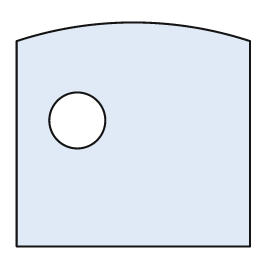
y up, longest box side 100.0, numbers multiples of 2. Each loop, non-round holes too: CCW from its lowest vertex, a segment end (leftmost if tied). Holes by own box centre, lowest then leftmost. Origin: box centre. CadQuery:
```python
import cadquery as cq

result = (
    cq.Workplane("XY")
    .moveTo(-50.0, -48.0)
    .lineTo(50.0, -48.0)
    .lineTo(50.0, 40.0)
    .threePointArc((0.0, 48.0), (-50.0, 40.0))
    .close()
    .moveTo(-24.0, 6.0)
    .circle(12.0)
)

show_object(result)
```